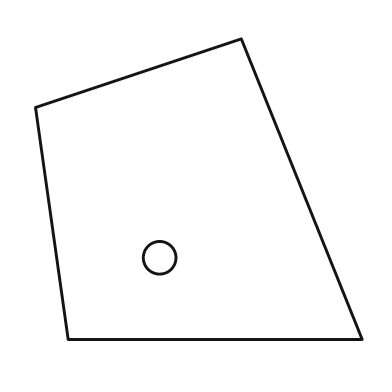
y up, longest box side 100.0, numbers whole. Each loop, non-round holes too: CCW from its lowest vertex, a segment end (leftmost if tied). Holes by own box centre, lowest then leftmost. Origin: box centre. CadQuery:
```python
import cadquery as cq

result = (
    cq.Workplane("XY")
    .moveTo(-40.0, -46.0)
    .lineTo(50.0, -46.0)
    .lineTo(13.0, 46.0)
    .lineTo(-50.0, 25.0)
    .close()
    .moveTo(-12.0, -21.0)
    .circle(5.0)
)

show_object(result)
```